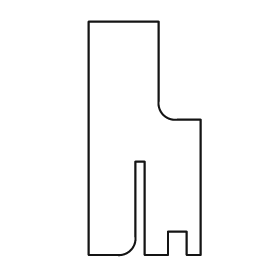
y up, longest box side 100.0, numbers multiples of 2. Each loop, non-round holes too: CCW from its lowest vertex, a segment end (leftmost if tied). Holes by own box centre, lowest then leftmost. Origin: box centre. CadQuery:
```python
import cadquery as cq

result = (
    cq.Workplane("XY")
    .moveTo(-24.0, -50.0)
    .lineTo(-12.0, -50.0)
    .threePointArc((-6.0, -48.0), (-4.0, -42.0))
    .lineTo(-4.0, -10.0)
    .lineTo(0.0, -10.0)
    .lineTo(0.0, -50.0)
    .lineTo(10.0, -50.0)
    .lineTo(10.0, -40.0)
    .lineTo(18.0, -40.0)
    .lineTo(18.0, -50.0)
    .lineTo(24.0, -50.0)
    .lineTo(24.0, 8.0)
    .lineTo(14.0, 8.0)
    .threePointArc((8.0, 10.0), (6.0, 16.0))
    .lineTo(6.0, 50.0)
    .lineTo(-24.0, 50.0)
    .close()
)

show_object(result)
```